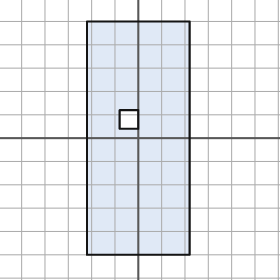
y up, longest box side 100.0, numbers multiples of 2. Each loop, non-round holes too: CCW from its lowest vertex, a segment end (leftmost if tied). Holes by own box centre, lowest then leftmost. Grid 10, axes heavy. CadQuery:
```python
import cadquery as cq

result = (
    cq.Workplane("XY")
    .moveTo(-22.0, -50.0)
    .lineTo(22.0, -50.0)
    .lineTo(22.0, 50.0)
    .lineTo(-22.0, 50.0)
    .close()
    .moveTo(-8.0, 4.0)
    .lineTo(0.0, 4.0)
    .lineTo(0.0, 12.0)
    .lineTo(-8.0, 12.0)
    .close()
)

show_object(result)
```